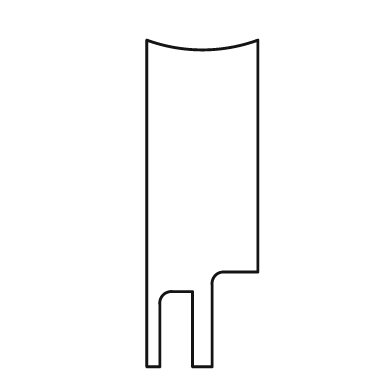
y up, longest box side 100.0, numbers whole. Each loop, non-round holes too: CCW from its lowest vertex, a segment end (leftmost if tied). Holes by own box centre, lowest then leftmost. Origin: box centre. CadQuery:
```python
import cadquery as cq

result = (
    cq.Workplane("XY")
    .moveTo(-17.0, -50.0)
    .lineTo(-13.0, -50.0)
    .lineTo(-13.0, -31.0)
    .threePointArc((-12.0, -28.0), (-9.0, -27.0))
    .lineTo(-3.0, -27.0)
    .lineTo(-3.0, -50.0)
    .lineTo(3.0, -50.0)
    .lineTo(3.0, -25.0)
    .threePointArc((4.0, -22.0), (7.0, -21.0))
    .lineTo(17.0, -21.0)
    .lineTo(17.0, 50.0)
    .threePointArc((0.0, 47.0), (-17.0, 50.0))
    .close()
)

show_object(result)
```